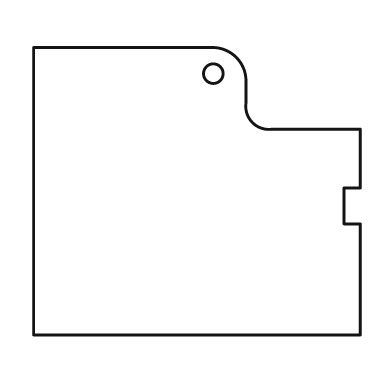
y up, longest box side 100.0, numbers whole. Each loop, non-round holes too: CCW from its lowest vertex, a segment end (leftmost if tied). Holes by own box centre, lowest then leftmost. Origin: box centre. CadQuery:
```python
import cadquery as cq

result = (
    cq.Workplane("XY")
    .moveTo(-50.0, -44.0)
    .lineTo(50.0, -44.0)
    .lineTo(50.0, -10.0)
    .lineTo(45.0, -10.0)
    .lineTo(45.0, 1.0)
    .lineTo(50.0, 1.0)
    .lineTo(50.0, 19.0)
    .lineTo(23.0, 19.0)
    .threePointArc((17.0, 21.0), (15.0, 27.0))
    .lineTo(15.0, 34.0)
    .threePointArc((12.0, 41.0), (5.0, 44.0))
    .lineTo(-50.0, 44.0)
    .close()
    .moveTo(5.0, 36.0)
    .circle(3.0)
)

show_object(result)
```